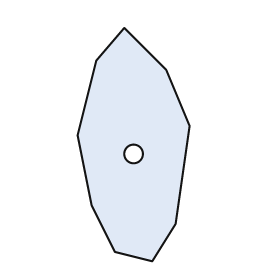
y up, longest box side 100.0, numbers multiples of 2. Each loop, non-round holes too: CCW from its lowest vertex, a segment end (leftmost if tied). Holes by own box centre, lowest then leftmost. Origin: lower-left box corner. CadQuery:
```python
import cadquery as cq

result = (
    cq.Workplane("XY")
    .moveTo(32.0, 0.0)
    .lineTo(42.0, 16.0)
    .lineTo(48.0, 58.0)
    .lineTo(38.0, 82.0)
    .lineTo(20.0, 100.0)
    .lineTo(8.0, 86.0)
    .lineTo(0.0, 54.0)
    .lineTo(6.0, 24.0)
    .lineTo(16.0, 4.0)
    .close()
    .moveTo(24.0, 46.0)
    .circle(4.0)
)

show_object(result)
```